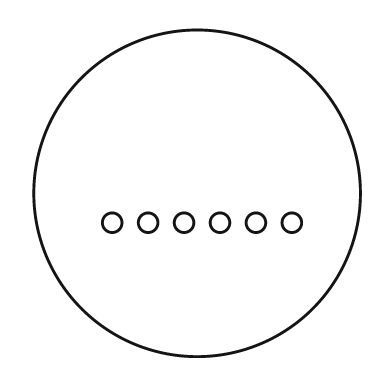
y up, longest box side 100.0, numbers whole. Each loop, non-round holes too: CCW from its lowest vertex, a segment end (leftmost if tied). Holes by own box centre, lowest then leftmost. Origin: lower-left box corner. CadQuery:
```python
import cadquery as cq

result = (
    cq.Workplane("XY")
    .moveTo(50.0, 50.0)
    .circle(50.0)
    .moveTo(24.0, 41.0)
    .circle(3.0)
    .moveTo(35.0, 41.0)
    .circle(3.0)
    .moveTo(46.0, 41.0)
    .circle(3.0)
    .moveTo(57.0, 41.0)
    .circle(3.0)
    .moveTo(68.0, 41.0)
    .circle(3.0)
    .moveTo(79.0, 41.0)
    .circle(3.0)
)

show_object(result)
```